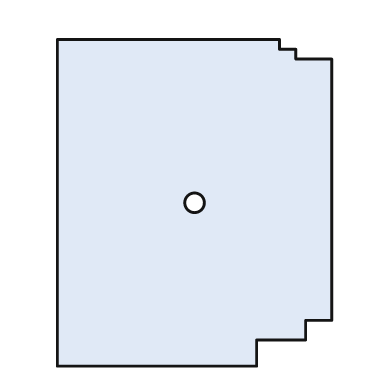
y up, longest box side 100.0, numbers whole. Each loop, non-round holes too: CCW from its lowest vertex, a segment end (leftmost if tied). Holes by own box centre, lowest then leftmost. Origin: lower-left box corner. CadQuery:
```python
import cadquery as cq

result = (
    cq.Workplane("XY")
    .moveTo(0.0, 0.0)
    .lineTo(61.0, 0.0)
    .lineTo(61.0, 8.0)
    .lineTo(76.0, 8.0)
    .lineTo(76.0, 14.0)
    .lineTo(84.0, 14.0)
    .lineTo(84.0, 94.0)
    .lineTo(73.0, 94.0)
    .lineTo(73.0, 97.0)
    .lineTo(68.0, 97.0)
    .lineTo(68.0, 100.0)
    .lineTo(0.0, 100.0)
    .close()
    .moveTo(42.0, 50.0)
    .circle(3.0)
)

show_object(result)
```